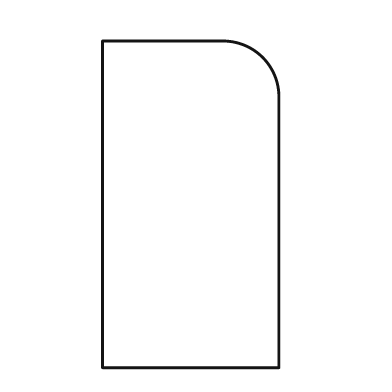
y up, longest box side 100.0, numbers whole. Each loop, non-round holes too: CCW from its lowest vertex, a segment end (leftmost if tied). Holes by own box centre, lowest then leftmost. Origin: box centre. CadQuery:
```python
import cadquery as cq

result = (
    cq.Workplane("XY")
    .moveTo(-27.0, -50.0)
    .lineTo(27.0, -50.0)
    .lineTo(27.0, 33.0)
    .threePointArc((22.0, 45.0), (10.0, 50.0))
    .lineTo(-27.0, 50.0)
    .close()
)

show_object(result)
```